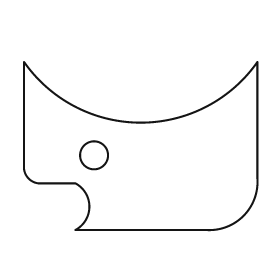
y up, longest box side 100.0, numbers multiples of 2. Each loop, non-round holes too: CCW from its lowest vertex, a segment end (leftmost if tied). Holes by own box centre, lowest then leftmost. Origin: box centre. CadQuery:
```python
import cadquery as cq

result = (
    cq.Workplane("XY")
    .moveTo(-28.0, -36.0)
    .lineTo(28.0, -36.0)
    .threePointArc((44.0, -30.0), (50.0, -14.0))
    .lineTo(50.0, 36.0)
    .threePointArc((0.0, 10.0), (-50.0, 36.0))
    .lineTo(-50.0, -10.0)
    .threePointArc((-48.0, -14.0), (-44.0, -16.0))
    .lineTo(-28.0, -16.0)
    .threePointArc((-22.0, -26.0), (-28.0, -36.0))
    .close()
    .moveTo(-20.0, -4.0)
    .circle(6.0)
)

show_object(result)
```